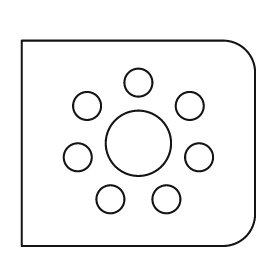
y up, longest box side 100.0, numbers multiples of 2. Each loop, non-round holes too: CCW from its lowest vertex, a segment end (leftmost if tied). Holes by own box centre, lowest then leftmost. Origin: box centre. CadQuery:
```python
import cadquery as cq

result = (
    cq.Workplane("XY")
    .moveTo(-50.0, -44.0)
    .lineTo(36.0, -44.0)
    .threePointArc((46.0, -40.0), (50.0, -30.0))
    .lineTo(50.0, 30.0)
    .threePointArc((46.0, 40.0), (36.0, 44.0))
    .lineTo(-50.0, 44.0)
    .close()
    .moveTo(-12.0, -24.0)
    .circle(6.0)
    .moveTo(12.0, -24.0)
    .circle(6.0)
    .moveTo(-26.0, -6.0)
    .circle(6.0)
    .moveTo(26.0, -6.0)
    .circle(6.0)
    .moveTo(0.0, 0.0)
    .circle(14.0)
    .moveTo(-22.0, 16.0)
    .circle(6.0)
    .moveTo(22.0, 16.0)
    .circle(6.0)
    .moveTo(0.0, 26.0)
    .circle(6.0)
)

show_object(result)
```